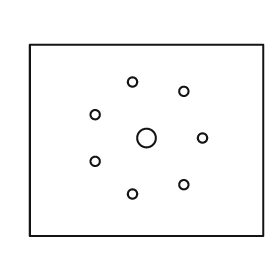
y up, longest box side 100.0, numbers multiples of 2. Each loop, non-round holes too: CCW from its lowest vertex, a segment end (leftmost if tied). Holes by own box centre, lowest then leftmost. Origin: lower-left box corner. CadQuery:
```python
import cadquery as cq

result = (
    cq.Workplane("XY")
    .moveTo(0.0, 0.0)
    .lineTo(100.0, 0.0)
    .lineTo(100.0, 82.0)
    .lineTo(0.0, 82.0)
    .close()
    .moveTo(44.0, 18.0)
    .circle(2.0)
    .moveTo(66.0, 22.0)
    .circle(2.0)
    .moveTo(28.0, 32.0)
    .circle(2.0)
    .moveTo(50.0, 42.0)
    .circle(4.0)
    .moveTo(74.0, 42.0)
    .circle(2.0)
    .moveTo(28.0, 52.0)
    .circle(2.0)
    .moveTo(66.0, 62.0)
    .circle(2.0)
    .moveTo(44.0, 66.0)
    .circle(2.0)
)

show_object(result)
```